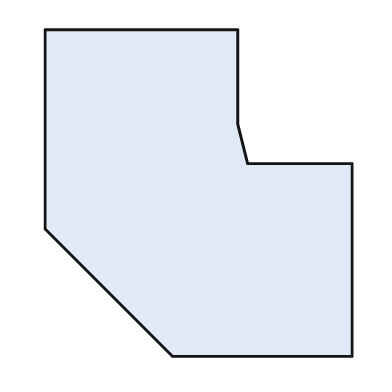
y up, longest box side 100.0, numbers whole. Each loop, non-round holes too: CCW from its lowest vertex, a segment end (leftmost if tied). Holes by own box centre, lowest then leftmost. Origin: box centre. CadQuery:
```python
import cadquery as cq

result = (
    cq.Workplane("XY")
    .moveTo(-8.0, -50.0)
    .lineTo(47.0, -50.0)
    .lineTo(47.0, 9.0)
    .lineTo(15.0, 9.0)
    .lineTo(12.0, 21.0)
    .lineTo(12.0, 50.0)
    .lineTo(-47.0, 50.0)
    .lineTo(-47.0, -11.0)
    .close()
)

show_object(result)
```